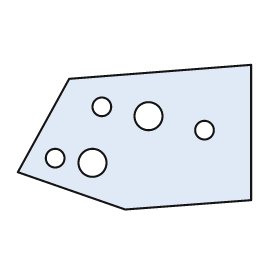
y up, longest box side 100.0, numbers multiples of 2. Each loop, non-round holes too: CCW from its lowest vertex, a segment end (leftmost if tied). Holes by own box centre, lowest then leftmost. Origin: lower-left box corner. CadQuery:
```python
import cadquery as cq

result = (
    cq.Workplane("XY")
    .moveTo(46.0, 0.0)
    .lineTo(100.0, 4.0)
    .lineTo(100.0, 62.0)
    .lineTo(22.0, 56.0)
    .lineTo(0.0, 16.0)
    .close()
    .moveTo(32.0, 20.0)
    .circle(6.0)
    .moveTo(16.0, 22.0)
    .circle(4.0)
    .moveTo(80.0, 34.0)
    .circle(4.0)
    .moveTo(56.0, 40.0)
    .circle(6.0)
    .moveTo(36.0, 44.0)
    .circle(4.0)
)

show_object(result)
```